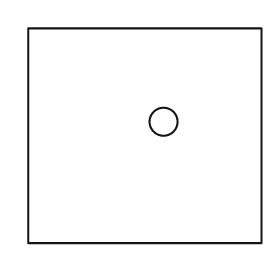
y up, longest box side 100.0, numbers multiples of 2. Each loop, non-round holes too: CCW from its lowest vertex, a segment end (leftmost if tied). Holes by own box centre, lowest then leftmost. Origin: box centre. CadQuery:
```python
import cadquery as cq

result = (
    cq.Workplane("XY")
    .moveTo(-50.0, -46.0)
    .lineTo(50.0, -46.0)
    .lineTo(50.0, 46.0)
    .lineTo(-50.0, 46.0)
    .close()
    .moveTo(8.0, 6.0)
    .circle(6.0)
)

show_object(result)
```